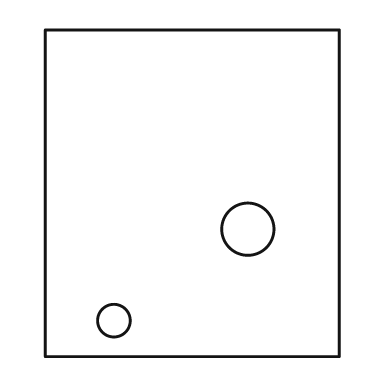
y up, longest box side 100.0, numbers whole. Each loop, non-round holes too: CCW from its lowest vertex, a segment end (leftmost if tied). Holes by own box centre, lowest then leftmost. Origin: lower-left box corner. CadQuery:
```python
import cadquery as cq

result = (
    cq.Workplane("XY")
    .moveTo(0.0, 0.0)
    .lineTo(90.0, 0.0)
    .lineTo(90.0, 100.0)
    .lineTo(0.0, 100.0)
    .close()
    .moveTo(21.0, 11.0)
    .circle(5.0)
    .moveTo(62.0, 39.0)
    .circle(8.0)
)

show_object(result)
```